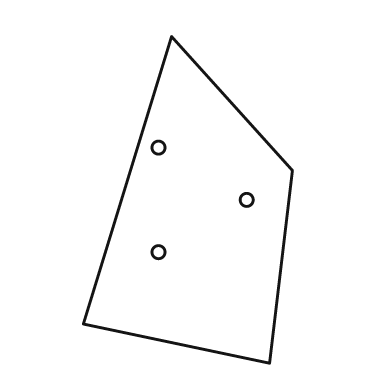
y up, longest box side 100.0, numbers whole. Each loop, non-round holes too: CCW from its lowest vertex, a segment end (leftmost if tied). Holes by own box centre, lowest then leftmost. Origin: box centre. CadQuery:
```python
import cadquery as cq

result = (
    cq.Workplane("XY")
    .moveTo(25.0, -50.0)
    .lineTo(32.0, 9.0)
    .lineTo(-5.0, 50.0)
    .lineTo(-32.0, -38.0)
    .close()
    .moveTo(-9.0, -16.0)
    .circle(2.0)
    .moveTo(18.0, 0.0)
    .circle(2.0)
    .moveTo(-9.0, 16.0)
    .circle(2.0)
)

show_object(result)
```